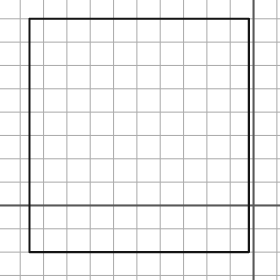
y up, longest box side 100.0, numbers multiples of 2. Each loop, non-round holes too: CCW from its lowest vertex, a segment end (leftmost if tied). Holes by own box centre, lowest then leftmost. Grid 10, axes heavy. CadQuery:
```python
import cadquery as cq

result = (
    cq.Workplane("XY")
    .moveTo(-96.0, -20.0)
    .lineTo(-2.0, -20.0)
    .lineTo(-2.0, 80.0)
    .lineTo(-96.0, 80.0)
    .close()
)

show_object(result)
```